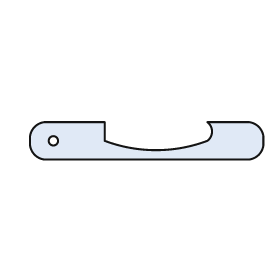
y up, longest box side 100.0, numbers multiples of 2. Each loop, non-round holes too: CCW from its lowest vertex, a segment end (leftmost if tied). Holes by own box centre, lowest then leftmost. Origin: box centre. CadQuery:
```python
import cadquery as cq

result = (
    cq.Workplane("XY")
    .moveTo(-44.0, -8.0)
    .lineTo(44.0, -8.0)
    .threePointArc((48.0, -6.0), (50.0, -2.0))
    .lineTo(50.0, 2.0)
    .threePointArc((48.0, 6.0), (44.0, 8.0))
    .lineTo(26.0, 8.0)
    .threePointArc((28.0, 4.0), (26.0, 0.0))
    .threePointArc((4.0, -4.0), (-18.0, 0.0))
    .lineTo(-18.0, 8.0)
    .lineTo(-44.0, 8.0)
    .threePointArc((-48.0, 6.0), (-50.0, 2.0))
    .lineTo(-50.0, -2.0)
    .threePointArc((-48.0, -6.0), (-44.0, -8.0))
    .close()
    .moveTo(-40.0, 0.0)
    .circle(2.0)
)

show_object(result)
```